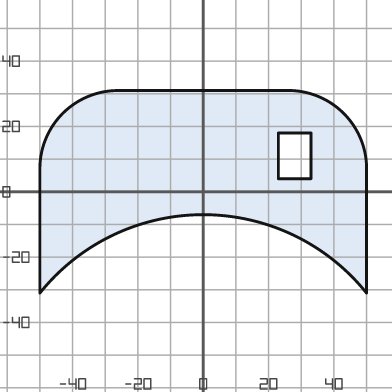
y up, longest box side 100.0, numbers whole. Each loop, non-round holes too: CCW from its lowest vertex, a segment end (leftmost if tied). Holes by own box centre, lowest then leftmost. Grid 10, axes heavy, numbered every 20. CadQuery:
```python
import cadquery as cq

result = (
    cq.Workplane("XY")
    .moveTo(-50.0, -31.0)
    .threePointArc((0.0, -7.0), (50.0, -31.0))
    .lineTo(50.0, 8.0)
    .threePointArc((43.0, 24.0), (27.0, 31.0))
    .lineTo(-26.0, 31.0)
    .threePointArc((-43.0, 24.0), (-50.0, 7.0))
    .close()
    .moveTo(23.0, 4.0)
    .lineTo(33.0, 4.0)
    .lineTo(33.0, 18.0)
    .lineTo(23.0, 18.0)
    .close()
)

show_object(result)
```